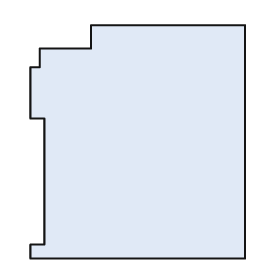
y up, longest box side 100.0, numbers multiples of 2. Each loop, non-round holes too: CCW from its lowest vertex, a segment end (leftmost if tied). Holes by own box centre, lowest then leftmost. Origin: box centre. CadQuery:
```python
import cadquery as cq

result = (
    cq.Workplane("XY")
    .moveTo(-46.0, -50.0)
    .lineTo(46.0, -50.0)
    .lineTo(46.0, 50.0)
    .lineTo(-20.0, 50.0)
    .lineTo(-20.0, 40.0)
    .lineTo(-42.0, 40.0)
    .lineTo(-42.0, 32.0)
    .lineTo(-46.0, 32.0)
    .lineTo(-46.0, 10.0)
    .lineTo(-40.0, 10.0)
    .lineTo(-40.0, -44.0)
    .lineTo(-46.0, -44.0)
    .close()
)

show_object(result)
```